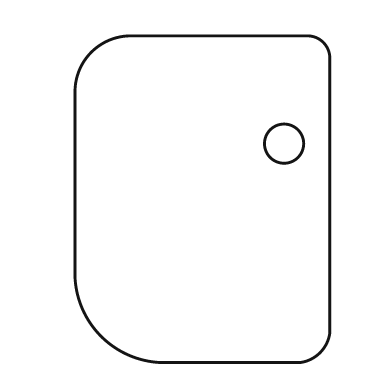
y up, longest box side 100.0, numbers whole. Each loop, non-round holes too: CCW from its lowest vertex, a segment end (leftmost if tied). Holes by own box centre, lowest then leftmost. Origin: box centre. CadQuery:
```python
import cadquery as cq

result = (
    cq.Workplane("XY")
    .moveTo(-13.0, -50.0)
    .lineTo(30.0, -50.0)
    .threePointArc((36.0, -47.0), (39.0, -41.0))
    .lineTo(39.0, 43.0)
    .threePointArc((37.0, 48.0), (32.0, 50.0))
    .lineTo(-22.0, 50.0)
    .threePointArc((-34.0, 45.0), (-39.0, 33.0))
    .lineTo(-39.0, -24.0)
    .threePointArc((-31.0, -42.0), (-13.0, -50.0))
    .close()
    .moveTo(25.0, 17.0)
    .circle(6.0)
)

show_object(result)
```